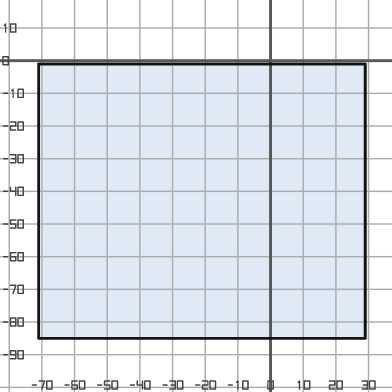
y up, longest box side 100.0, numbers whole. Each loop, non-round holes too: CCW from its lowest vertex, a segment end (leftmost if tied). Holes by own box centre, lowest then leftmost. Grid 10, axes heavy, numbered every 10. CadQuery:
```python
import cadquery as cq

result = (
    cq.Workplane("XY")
    .moveTo(-71.0, -85.0)
    .lineTo(29.0, -85.0)
    .lineTo(29.0, -1.0)
    .lineTo(-71.0, -1.0)
    .close()
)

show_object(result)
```